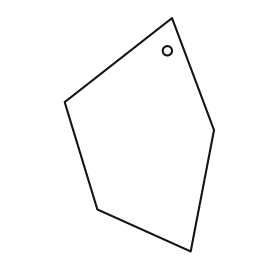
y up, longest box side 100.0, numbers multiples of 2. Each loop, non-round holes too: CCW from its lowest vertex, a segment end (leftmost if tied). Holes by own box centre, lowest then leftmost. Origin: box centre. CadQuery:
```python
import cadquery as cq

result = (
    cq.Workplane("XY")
    .moveTo(22.0, -50.0)
    .lineTo(32.0, 2.0)
    .lineTo(14.0, 50.0)
    .lineTo(-32.0, 14.0)
    .lineTo(-18.0, -32.0)
    .close()
    .moveTo(12.0, 36.0)
    .circle(2.0)
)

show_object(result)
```